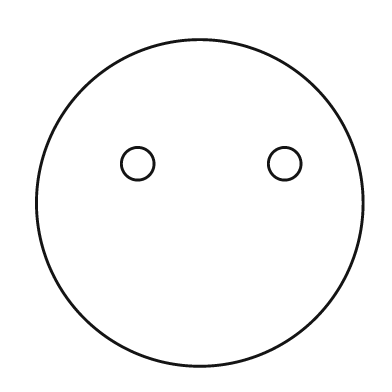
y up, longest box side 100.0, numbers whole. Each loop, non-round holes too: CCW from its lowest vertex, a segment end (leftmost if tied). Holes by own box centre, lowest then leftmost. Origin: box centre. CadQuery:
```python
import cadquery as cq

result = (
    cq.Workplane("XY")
    .moveTo(0.0, 0.0)
    .circle(50.0)
    .moveTo(-19.0, 12.0)
    .circle(5.0)
    .moveTo(26.0, 12.0)
    .circle(5.0)
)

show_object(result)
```